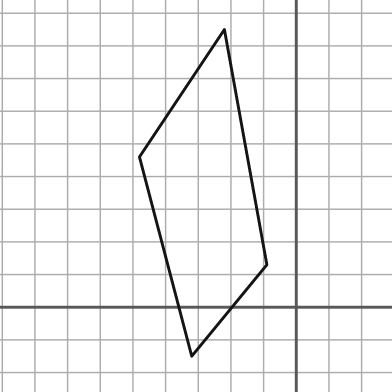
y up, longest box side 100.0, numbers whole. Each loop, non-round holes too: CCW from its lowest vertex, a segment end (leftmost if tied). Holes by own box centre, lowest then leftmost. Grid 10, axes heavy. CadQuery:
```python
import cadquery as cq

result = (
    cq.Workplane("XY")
    .moveTo(-32.0, -15.0)
    .lineTo(-9.0, 13.0)
    .lineTo(-22.0, 85.0)
    .lineTo(-48.0, 46.0)
    .close()
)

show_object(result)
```